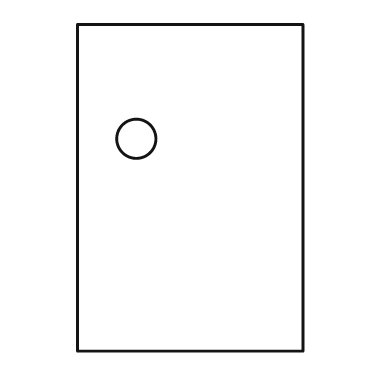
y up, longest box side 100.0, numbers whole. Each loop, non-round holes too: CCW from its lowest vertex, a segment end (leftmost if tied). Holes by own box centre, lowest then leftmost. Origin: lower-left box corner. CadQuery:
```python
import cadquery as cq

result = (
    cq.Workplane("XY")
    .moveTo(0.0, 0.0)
    .lineTo(69.0, 0.0)
    .lineTo(69.0, 100.0)
    .lineTo(0.0, 100.0)
    .close()
    .moveTo(18.0, 65.0)
    .circle(6.0)
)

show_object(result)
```